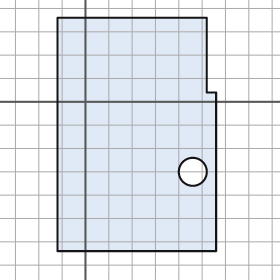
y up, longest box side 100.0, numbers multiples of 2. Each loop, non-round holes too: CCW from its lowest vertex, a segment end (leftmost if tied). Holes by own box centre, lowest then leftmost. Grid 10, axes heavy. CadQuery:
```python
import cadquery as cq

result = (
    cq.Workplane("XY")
    .moveTo(-12.0, -64.0)
    .lineTo(56.0, -64.0)
    .lineTo(56.0, 4.0)
    .lineTo(52.0, 4.0)
    .lineTo(52.0, 36.0)
    .lineTo(-12.0, 36.0)
    .close()
    .moveTo(46.0, -30.0)
    .circle(6.0)
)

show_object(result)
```